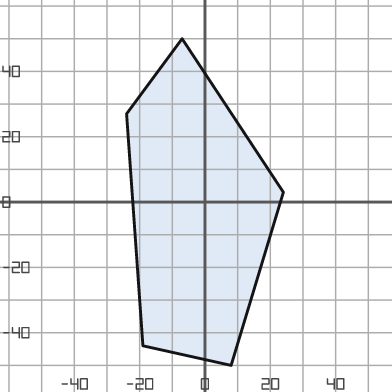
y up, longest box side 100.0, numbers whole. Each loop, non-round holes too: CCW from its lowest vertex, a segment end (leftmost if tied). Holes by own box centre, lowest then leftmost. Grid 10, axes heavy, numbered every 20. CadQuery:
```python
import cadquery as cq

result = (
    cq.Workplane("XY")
    .moveTo(8.0, -50.0)
    .lineTo(24.0, 3.0)
    .lineTo(-7.0, 50.0)
    .lineTo(-24.0, 27.0)
    .lineTo(-19.0, -44.0)
    .close()
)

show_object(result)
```